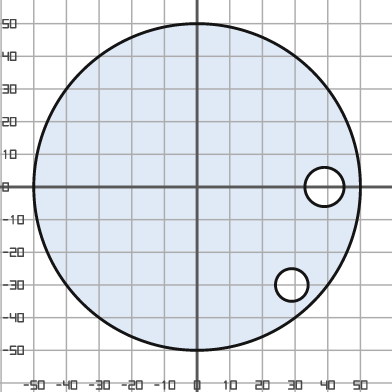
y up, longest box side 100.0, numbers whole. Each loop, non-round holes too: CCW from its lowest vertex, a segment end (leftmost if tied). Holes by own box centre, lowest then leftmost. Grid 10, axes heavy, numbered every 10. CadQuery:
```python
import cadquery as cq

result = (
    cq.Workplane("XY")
    .moveTo(0.0, 0.0)
    .circle(50.0)
    .moveTo(29.0, -30.0)
    .circle(5.0)
    .moveTo(39.0, 0.0)
    .circle(6.0)
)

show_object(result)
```